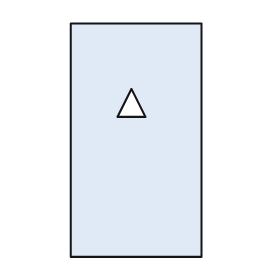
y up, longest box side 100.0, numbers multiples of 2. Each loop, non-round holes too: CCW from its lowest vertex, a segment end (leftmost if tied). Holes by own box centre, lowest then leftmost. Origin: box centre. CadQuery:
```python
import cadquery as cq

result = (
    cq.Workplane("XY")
    .moveTo(-28.0, -50.0)
    .lineTo(28.0, -50.0)
    .lineTo(28.0, 50.0)
    .lineTo(-28.0, 50.0)
    .close()
    .moveTo(-8.0, 10.0)
    .lineTo(4.0, 10.0)
    .lineTo(-2.0, 22.0)
    .close()
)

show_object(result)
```